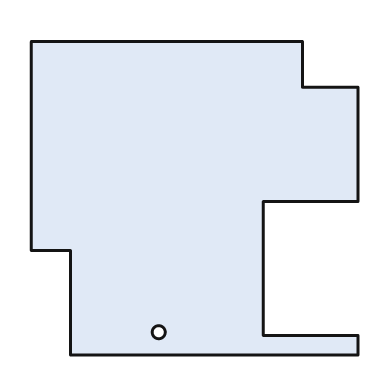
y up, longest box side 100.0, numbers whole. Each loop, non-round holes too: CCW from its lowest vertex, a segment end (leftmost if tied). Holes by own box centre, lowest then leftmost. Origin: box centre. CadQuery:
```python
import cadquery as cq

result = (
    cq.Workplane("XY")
    .moveTo(-38.0, -48.0)
    .lineTo(50.0, -48.0)
    .lineTo(50.0, -42.0)
    .lineTo(21.0, -42.0)
    .lineTo(21.0, -1.0)
    .lineTo(50.0, -1.0)
    .lineTo(50.0, 34.0)
    .lineTo(33.0, 34.0)
    .lineTo(33.0, 48.0)
    .lineTo(-50.0, 48.0)
    .lineTo(-50.0, -16.0)
    .lineTo(-38.0, -16.0)
    .close()
    .moveTo(-11.0, -41.0)
    .circle(2.0)
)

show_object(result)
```